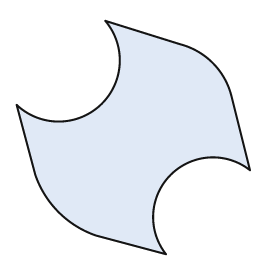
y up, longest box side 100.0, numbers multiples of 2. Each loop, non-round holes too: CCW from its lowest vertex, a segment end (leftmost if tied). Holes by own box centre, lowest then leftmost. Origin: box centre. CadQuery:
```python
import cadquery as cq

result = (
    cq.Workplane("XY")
    .moveTo(14.0, -50.0)
    .threePointArc((16.0, -16.0), (50.0, -14.0))
    .lineTo(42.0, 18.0)
    .threePointArc((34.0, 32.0), (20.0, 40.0))
    .lineTo(-12.0, 50.0)
    .threePointArc((-14.0, 14.0), (-50.0, 14.0))
    .lineTo(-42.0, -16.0)
    .threePointArc((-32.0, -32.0), (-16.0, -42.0))
    .close()
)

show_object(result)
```